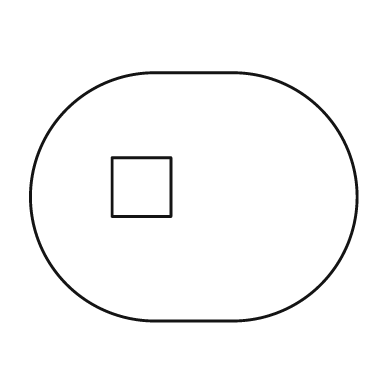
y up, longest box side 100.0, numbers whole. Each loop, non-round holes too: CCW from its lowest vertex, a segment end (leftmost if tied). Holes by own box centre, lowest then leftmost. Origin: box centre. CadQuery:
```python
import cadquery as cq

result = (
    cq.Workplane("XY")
    .moveTo(-12.0, -38.0)
    .lineTo(12.0, -38.0)
    .threePointArc((50.0, 0.0), (12.0, 38.0))
    .lineTo(-12.0, 38.0)
    .threePointArc((-50.0, 0.0), (-12.0, -38.0))
    .close()
    .moveTo(-25.0, -6.0)
    .lineTo(-7.0, -6.0)
    .lineTo(-7.0, 12.0)
    .lineTo(-25.0, 12.0)
    .close()
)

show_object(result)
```